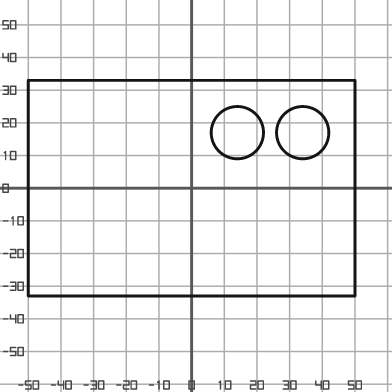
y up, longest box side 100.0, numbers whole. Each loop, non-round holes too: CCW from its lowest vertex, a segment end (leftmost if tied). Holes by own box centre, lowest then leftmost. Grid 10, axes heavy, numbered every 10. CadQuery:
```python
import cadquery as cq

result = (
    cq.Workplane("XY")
    .moveTo(-50.0, -33.0)
    .lineTo(50.0, -33.0)
    .lineTo(50.0, 33.0)
    .lineTo(-50.0, 33.0)
    .close()
    .moveTo(14.0, 17.0)
    .circle(8.0)
    .moveTo(34.0, 17.0)
    .circle(8.0)
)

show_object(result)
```